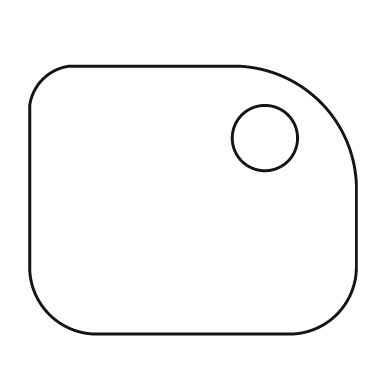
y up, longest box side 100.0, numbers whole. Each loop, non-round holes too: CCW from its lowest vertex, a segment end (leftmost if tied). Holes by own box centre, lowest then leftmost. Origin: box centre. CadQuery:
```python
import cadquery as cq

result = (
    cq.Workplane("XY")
    .moveTo(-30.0, -41.0)
    .lineTo(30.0, -41.0)
    .threePointArc((44.0, -35.0), (50.0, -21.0))
    .lineTo(50.0, 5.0)
    .threePointArc((39.0, 30.0), (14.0, 41.0))
    .lineTo(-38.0, 41.0)
    .threePointArc((-46.0, 37.0), (-50.0, 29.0))
    .lineTo(-50.0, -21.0)
    .threePointArc((-44.0, -35.0), (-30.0, -41.0))
    .close()
    .moveTo(22.0, 19.0)
    .circle(10.0)
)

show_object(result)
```